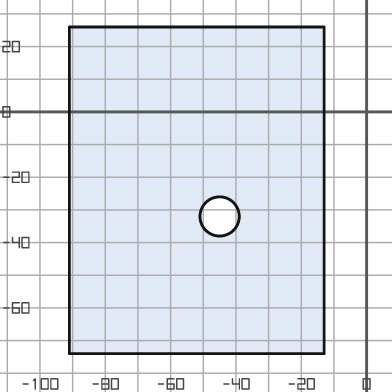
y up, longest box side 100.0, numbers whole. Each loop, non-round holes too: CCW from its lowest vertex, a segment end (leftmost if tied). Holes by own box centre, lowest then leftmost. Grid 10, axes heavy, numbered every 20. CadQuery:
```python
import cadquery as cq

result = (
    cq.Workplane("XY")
    .moveTo(-91.0, -74.0)
    .lineTo(-13.0, -74.0)
    .lineTo(-13.0, 26.0)
    .lineTo(-91.0, 26.0)
    .close()
    .moveTo(-45.0, -32.0)
    .circle(6.0)
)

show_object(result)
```